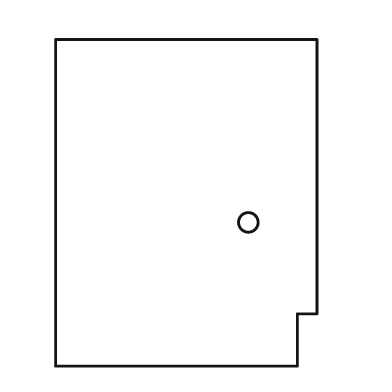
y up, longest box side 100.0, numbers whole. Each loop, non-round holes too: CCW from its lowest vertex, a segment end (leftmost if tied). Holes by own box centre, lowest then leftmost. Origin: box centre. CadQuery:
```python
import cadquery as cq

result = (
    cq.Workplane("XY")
    .moveTo(-40.0, -50.0)
    .lineTo(34.0, -50.0)
    .lineTo(34.0, -34.0)
    .lineTo(40.0, -34.0)
    .lineTo(40.0, 50.0)
    .lineTo(-40.0, 50.0)
    .close()
    .moveTo(19.0, -6.0)
    .circle(3.0)
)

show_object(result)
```